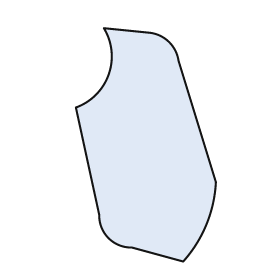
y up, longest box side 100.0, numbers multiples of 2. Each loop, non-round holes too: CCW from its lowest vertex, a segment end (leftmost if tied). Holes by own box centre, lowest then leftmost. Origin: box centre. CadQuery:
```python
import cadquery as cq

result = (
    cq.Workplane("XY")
    .moveTo(16.0, -50.0)
    .threePointArc((26.0, -34.0), (30.0, -16.0))
    .lineTo(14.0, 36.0)
    .threePointArc((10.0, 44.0), (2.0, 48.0))
    .lineTo(-18.0, 50.0)
    .threePointArc((-16.0, 30.0), (-30.0, 16.0))
    .lineTo(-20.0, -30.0)
    .threePointArc((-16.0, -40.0), (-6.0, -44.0))
    .close()
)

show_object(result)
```